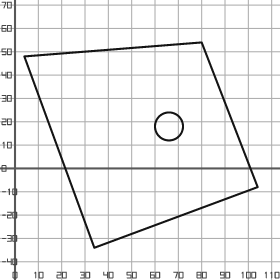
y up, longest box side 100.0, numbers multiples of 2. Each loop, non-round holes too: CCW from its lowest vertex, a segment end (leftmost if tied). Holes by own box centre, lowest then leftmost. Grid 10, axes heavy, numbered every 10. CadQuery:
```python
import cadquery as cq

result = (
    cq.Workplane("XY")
    .moveTo(34.0, -34.0)
    .lineTo(104.0, -8.0)
    .lineTo(80.0, 54.0)
    .lineTo(4.0, 48.0)
    .close()
    .moveTo(66.0, 18.0)
    .circle(6.0)
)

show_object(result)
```